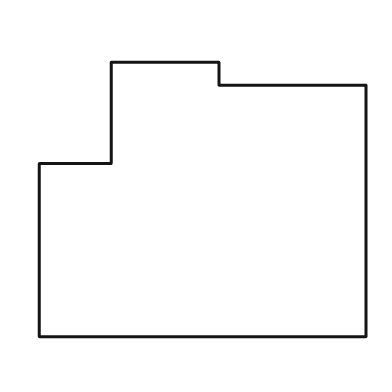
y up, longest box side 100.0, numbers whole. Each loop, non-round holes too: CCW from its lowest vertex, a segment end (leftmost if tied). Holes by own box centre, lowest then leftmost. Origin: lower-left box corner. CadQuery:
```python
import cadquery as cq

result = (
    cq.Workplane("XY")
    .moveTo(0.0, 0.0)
    .lineTo(100.0, 0.0)
    .lineTo(100.0, 77.0)
    .lineTo(55.0, 77.0)
    .lineTo(55.0, 84.0)
    .lineTo(22.0, 84.0)
    .lineTo(22.0, 53.0)
    .lineTo(0.0, 53.0)
    .close()
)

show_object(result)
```